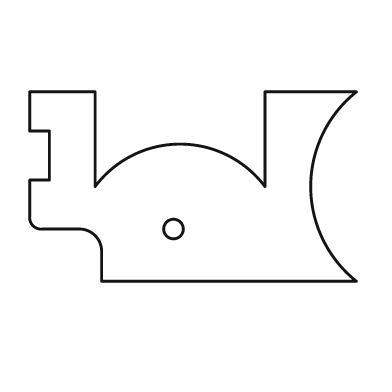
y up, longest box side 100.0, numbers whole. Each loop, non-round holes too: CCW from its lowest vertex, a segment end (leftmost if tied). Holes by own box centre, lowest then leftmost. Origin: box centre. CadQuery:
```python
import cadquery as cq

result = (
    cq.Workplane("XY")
    .moveTo(-28.0, -29.0)
    .lineTo(50.0, -29.0)
    .threePointArc((36.0, 0.0), (50.0, 29.0))
    .lineTo(22.0, 29.0)
    .lineTo(22.0, 0.0)
    .threePointArc((-4.0, 13.0), (-30.0, 0.0))
    .lineTo(-30.0, 29.0)
    .lineTo(-50.0, 29.0)
    .lineTo(-50.0, 17.0)
    .lineTo(-44.0, 17.0)
    .lineTo(-44.0, 2.0)
    .lineTo(-50.0, 2.0)
    .lineTo(-50.0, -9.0)
    .threePointArc((-49.0, -12.0), (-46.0, -13.0))
    .lineTo(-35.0, -13.0)
    .threePointArc((-30.0, -15.0), (-28.0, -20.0))
    .close()
    .moveTo(-6.0, -13.0)
    .circle(3.0)
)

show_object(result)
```